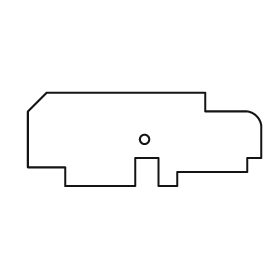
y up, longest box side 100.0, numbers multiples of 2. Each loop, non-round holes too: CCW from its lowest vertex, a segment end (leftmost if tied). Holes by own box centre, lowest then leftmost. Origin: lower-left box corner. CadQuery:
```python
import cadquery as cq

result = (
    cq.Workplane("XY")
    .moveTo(16.0, 0.0)
    .lineTo(46.0, 0.0)
    .lineTo(46.0, 12.0)
    .lineTo(56.0, 12.0)
    .lineTo(56.0, 0.0)
    .lineTo(64.0, 0.0)
    .lineTo(64.0, 6.0)
    .lineTo(94.0, 6.0)
    .lineTo(94.0, 12.0)
    .lineTo(100.0, 12.0)
    .lineTo(100.0, 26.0)
    .threePointArc((98.0, 30.0), (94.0, 32.0))
    .lineTo(76.0, 32.0)
    .lineTo(76.0, 40.0)
    .lineTo(8.0, 40.0)
    .lineTo(0.0, 32.0)
    .lineTo(0.0, 8.0)
    .lineTo(16.0, 8.0)
    .close()
    .moveTo(50.0, 20.0)
    .circle(2.0)
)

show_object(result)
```